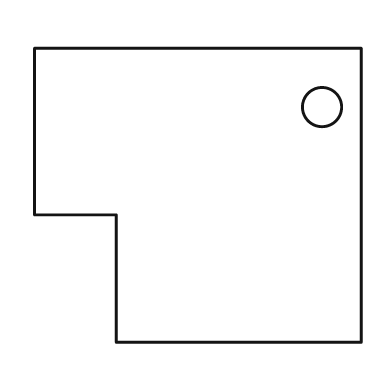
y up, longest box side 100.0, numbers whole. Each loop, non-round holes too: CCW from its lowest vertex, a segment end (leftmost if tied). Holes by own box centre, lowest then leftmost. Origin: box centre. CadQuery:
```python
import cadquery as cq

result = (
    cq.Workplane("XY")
    .moveTo(-25.0, -45.0)
    .lineTo(50.0, -45.0)
    .lineTo(50.0, 45.0)
    .lineTo(-50.0, 45.0)
    .lineTo(-50.0, -6.0)
    .lineTo(-25.0, -6.0)
    .close()
    .moveTo(38.0, 27.0)
    .circle(6.0)
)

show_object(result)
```